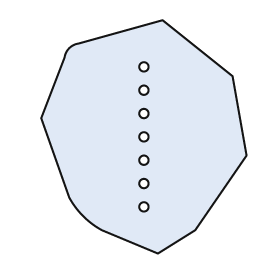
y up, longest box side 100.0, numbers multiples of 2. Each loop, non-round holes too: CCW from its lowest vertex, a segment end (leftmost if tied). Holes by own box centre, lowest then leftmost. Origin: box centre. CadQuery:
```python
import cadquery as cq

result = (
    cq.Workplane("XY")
    .moveTo(6.0, -50.0)
    .lineTo(22.0, -40.0)
    .lineTo(44.0, -8.0)
    .lineTo(38.0, 26.0)
    .lineTo(8.0, 50.0)
    .lineTo(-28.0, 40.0)
    .threePointArc((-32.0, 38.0), (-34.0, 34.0))
    .lineTo(-44.0, 8.0)
    .lineTo(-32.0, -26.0)
    .threePointArc((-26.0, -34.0), (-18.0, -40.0))
    .close()
    .moveTo(0.0, -30.0)
    .circle(2.0)
    .moveTo(0.0, -20.0)
    .circle(2.0)
    .moveTo(0.0, -10.0)
    .circle(2.0)
    .moveTo(0.0, 0.0)
    .circle(2.0)
    .moveTo(0.0, 10.0)
    .circle(2.0)
    .moveTo(0.0, 20.0)
    .circle(2.0)
    .moveTo(0.0, 30.0)
    .circle(2.0)
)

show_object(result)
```